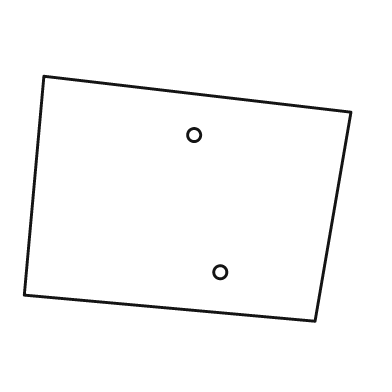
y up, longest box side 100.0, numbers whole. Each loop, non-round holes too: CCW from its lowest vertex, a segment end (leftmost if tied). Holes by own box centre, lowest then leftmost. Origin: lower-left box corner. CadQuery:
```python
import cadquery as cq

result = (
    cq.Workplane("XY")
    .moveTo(89.0, 0.0)
    .lineTo(100.0, 64.0)
    .lineTo(6.0, 75.0)
    .lineTo(0.0, 8.0)
    .close()
    .moveTo(60.0, 15.0)
    .circle(2.0)
    .moveTo(52.0, 57.0)
    .circle(2.0)
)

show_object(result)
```